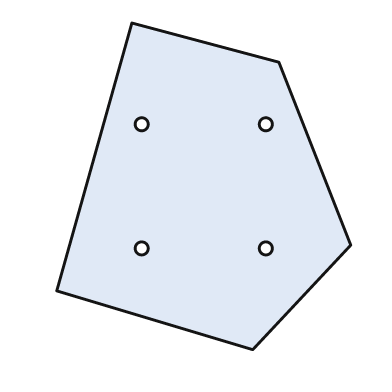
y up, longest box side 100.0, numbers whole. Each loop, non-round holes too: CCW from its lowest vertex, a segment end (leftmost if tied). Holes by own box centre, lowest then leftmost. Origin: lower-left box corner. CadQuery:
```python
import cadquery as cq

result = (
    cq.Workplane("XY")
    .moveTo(60.0, 0.0)
    .lineTo(90.0, 32.0)
    .lineTo(68.0, 88.0)
    .lineTo(23.0, 100.0)
    .lineTo(0.0, 18.0)
    .close()
    .moveTo(26.0, 31.0)
    .circle(2.0)
    .moveTo(64.0, 31.0)
    .circle(2.0)
    .moveTo(26.0, 69.0)
    .circle(2.0)
    .moveTo(64.0, 69.0)
    .circle(2.0)
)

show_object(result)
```